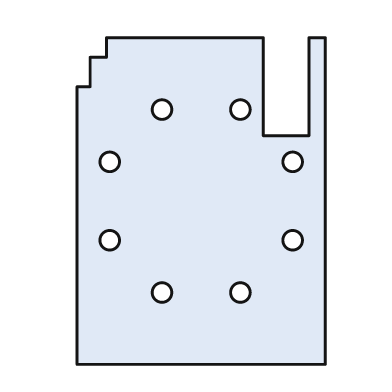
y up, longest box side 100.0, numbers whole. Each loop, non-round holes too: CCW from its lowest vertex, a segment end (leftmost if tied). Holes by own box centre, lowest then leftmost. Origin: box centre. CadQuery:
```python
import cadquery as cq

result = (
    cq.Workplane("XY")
    .moveTo(-38.0, -50.0)
    .lineTo(38.0, -50.0)
    .lineTo(38.0, 50.0)
    .lineTo(33.0, 50.0)
    .lineTo(33.0, 20.0)
    .lineTo(19.0, 20.0)
    .lineTo(19.0, 50.0)
    .lineTo(-29.0, 50.0)
    .lineTo(-29.0, 44.0)
    .lineTo(-34.0, 44.0)
    .lineTo(-34.0, 35.0)
    .lineTo(-38.0, 35.0)
    .close()
    .moveTo(-12.0, -28.0)
    .circle(3.0)
    .moveTo(12.0, -28.0)
    .circle(3.0)
    .moveTo(-28.0, -12.0)
    .circle(3.0)
    .moveTo(28.0, -12.0)
    .circle(3.0)
    .moveTo(-28.0, 12.0)
    .circle(3.0)
    .moveTo(28.0, 12.0)
    .circle(3.0)
    .moveTo(-12.0, 28.0)
    .circle(3.0)
    .moveTo(12.0, 28.0)
    .circle(3.0)
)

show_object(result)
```